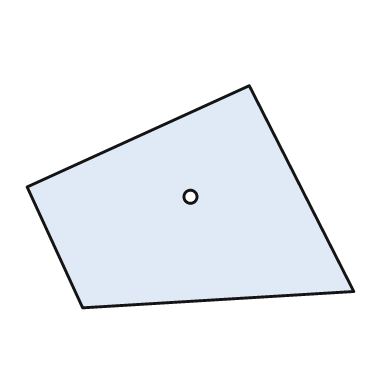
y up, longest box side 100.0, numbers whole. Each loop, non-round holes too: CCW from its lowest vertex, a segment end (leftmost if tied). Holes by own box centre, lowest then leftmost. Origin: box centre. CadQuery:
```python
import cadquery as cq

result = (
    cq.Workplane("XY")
    .moveTo(-33.0, -34.0)
    .lineTo(50.0, -29.0)
    .lineTo(18.0, 34.0)
    .lineTo(-50.0, 3.0)
    .close()
    .moveTo(0.0, 0.0)
    .circle(2.0)
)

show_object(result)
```